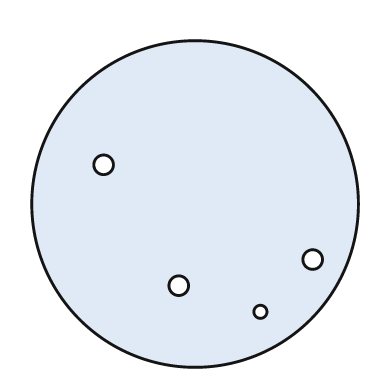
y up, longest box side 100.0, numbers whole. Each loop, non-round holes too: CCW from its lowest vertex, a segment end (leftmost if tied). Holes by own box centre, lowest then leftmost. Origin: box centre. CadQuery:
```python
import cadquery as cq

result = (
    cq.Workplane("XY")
    .moveTo(0.0, 0.0)
    .circle(50.0)
    .moveTo(20.0, -33.0)
    .circle(2.0)
    .moveTo(-5.0, -25.0)
    .circle(3.0)
    .moveTo(36.0, -17.0)
    .circle(3.0)
    .moveTo(-28.0, 12.0)
    .circle(3.0)
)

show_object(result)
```